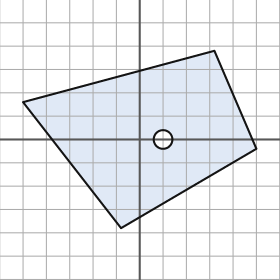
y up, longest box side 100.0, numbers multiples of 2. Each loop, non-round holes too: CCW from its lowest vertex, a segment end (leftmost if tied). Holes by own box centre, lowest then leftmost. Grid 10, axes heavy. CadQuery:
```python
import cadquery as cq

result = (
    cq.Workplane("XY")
    .moveTo(-8.0, -38.0)
    .lineTo(50.0, -4.0)
    .lineTo(32.0, 38.0)
    .lineTo(-50.0, 16.0)
    .close()
    .moveTo(10.0, 0.0)
    .circle(4.0)
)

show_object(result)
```